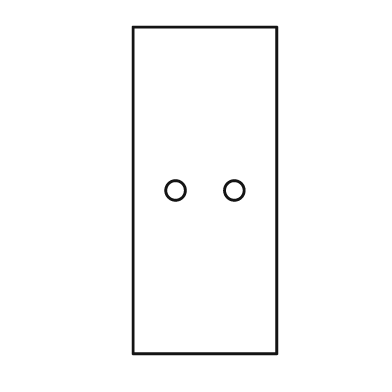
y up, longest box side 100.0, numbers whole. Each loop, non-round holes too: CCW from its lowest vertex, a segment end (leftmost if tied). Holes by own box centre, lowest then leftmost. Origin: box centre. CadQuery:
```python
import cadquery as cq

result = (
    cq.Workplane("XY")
    .moveTo(-22.0, -50.0)
    .lineTo(22.0, -50.0)
    .lineTo(22.0, 50.0)
    .lineTo(-22.0, 50.0)
    .close()
    .moveTo(-9.0, 0.0)
    .circle(3.0)
    .moveTo(9.0, 0.0)
    .circle(3.0)
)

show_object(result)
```